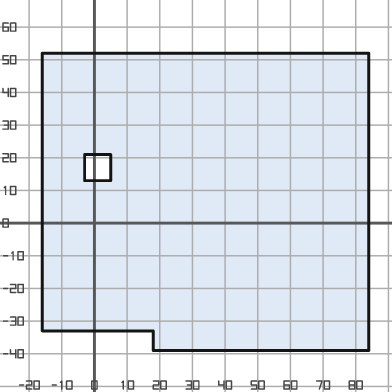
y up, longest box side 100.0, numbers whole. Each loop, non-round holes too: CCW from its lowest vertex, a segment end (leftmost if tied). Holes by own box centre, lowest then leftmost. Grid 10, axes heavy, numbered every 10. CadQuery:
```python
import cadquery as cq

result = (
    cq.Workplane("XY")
    .moveTo(18.0, -39.0)
    .lineTo(84.0, -39.0)
    .lineTo(84.0, 52.0)
    .lineTo(-16.0, 52.0)
    .lineTo(-16.0, -33.0)
    .lineTo(18.0, -33.0)
    .close()
    .moveTo(-3.0, 13.0)
    .lineTo(5.0, 13.0)
    .lineTo(5.0, 21.0)
    .lineTo(-3.0, 21.0)
    .close()
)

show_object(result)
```